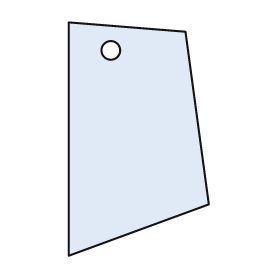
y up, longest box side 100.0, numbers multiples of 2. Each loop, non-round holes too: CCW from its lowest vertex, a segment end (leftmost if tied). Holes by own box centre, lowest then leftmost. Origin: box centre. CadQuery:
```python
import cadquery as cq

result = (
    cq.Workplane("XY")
    .moveTo(-30.0, -50.0)
    .lineTo(30.0, -28.0)
    .lineTo(20.0, 46.0)
    .lineTo(-30.0, 50.0)
    .close()
    .moveTo(-12.0, 38.0)
    .circle(4.0)
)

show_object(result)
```